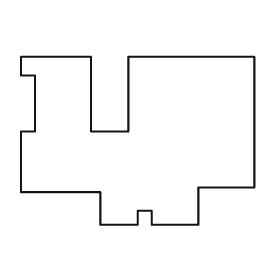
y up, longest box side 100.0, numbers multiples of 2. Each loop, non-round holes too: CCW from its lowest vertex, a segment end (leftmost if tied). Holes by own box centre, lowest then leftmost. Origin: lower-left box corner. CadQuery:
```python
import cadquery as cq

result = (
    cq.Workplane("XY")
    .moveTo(34.0, 0.0)
    .lineTo(50.0, 0.0)
    .lineTo(50.0, 6.0)
    .lineTo(56.0, 6.0)
    .lineTo(56.0, 0.0)
    .lineTo(76.0, 0.0)
    .lineTo(76.0, 16.0)
    .lineTo(100.0, 16.0)
    .lineTo(100.0, 72.0)
    .lineTo(46.0, 72.0)
    .lineTo(46.0, 40.0)
    .lineTo(30.0, 40.0)
    .lineTo(30.0, 72.0)
    .lineTo(0.0, 72.0)
    .lineTo(0.0, 64.0)
    .lineTo(6.0, 64.0)
    .lineTo(6.0, 40.0)
    .lineTo(0.0, 40.0)
    .lineTo(0.0, 14.0)
    .lineTo(34.0, 14.0)
    .close()
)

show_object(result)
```